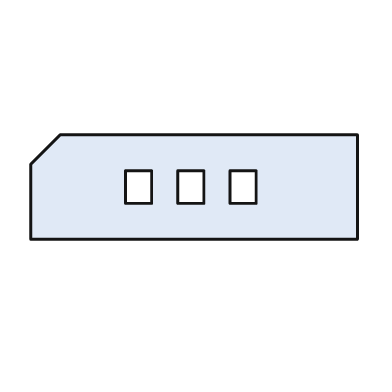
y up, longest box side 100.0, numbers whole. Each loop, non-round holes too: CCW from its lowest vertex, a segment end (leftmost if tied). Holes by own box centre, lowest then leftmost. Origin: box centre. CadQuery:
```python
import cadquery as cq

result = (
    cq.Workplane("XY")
    .moveTo(-50.0, -16.0)
    .lineTo(50.0, -16.0)
    .lineTo(50.0, 16.0)
    .lineTo(-41.0, 16.0)
    .lineTo(-50.0, 7.0)
    .close()
    .moveTo(-21.0, -5.0)
    .lineTo(-13.0, -5.0)
    .lineTo(-13.0, 5.0)
    .lineTo(-21.0, 5.0)
    .close()
    .moveTo(-5.0, -5.0)
    .lineTo(3.0, -5.0)
    .lineTo(3.0, 5.0)
    .lineTo(-5.0, 5.0)
    .close()
    .moveTo(11.0, -5.0)
    .lineTo(19.0, -5.0)
    .lineTo(19.0, 5.0)
    .lineTo(11.0, 5.0)
    .close()
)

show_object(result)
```